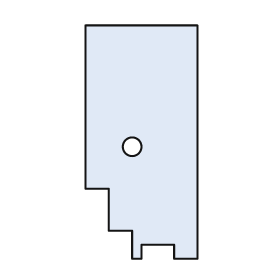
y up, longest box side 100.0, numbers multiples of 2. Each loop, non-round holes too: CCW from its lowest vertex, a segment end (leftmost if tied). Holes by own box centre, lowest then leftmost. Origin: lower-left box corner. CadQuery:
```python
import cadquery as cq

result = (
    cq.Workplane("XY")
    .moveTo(20.0, 0.0)
    .lineTo(24.0, 0.0)
    .lineTo(24.0, 6.0)
    .lineTo(38.0, 6.0)
    .lineTo(38.0, 0.0)
    .lineTo(48.0, 0.0)
    .lineTo(48.0, 100.0)
    .lineTo(0.0, 100.0)
    .lineTo(0.0, 30.0)
    .lineTo(10.0, 30.0)
    .lineTo(10.0, 12.0)
    .lineTo(20.0, 12.0)
    .close()
    .moveTo(20.0, 48.0)
    .circle(4.0)
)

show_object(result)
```